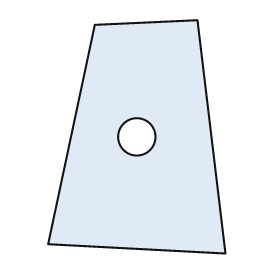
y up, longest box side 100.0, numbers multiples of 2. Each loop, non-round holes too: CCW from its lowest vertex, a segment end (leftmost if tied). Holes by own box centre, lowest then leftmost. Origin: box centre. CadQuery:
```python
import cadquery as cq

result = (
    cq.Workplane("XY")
    .moveTo(38.0, -50.0)
    .lineTo(26.0, 50.0)
    .lineTo(-18.0, 48.0)
    .lineTo(-38.0, -46.0)
    .close()
    .moveTo(0.0, 0.0)
    .circle(8.0)
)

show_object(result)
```